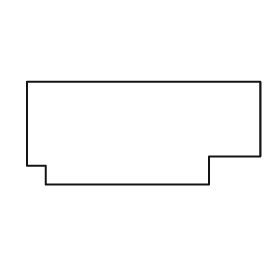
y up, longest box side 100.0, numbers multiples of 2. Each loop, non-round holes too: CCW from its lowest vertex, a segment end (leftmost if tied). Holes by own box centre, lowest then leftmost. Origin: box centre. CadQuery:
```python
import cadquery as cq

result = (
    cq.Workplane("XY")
    .moveTo(-42.0, -22.0)
    .lineTo(28.0, -22.0)
    .lineTo(28.0, -10.0)
    .lineTo(50.0, -10.0)
    .lineTo(50.0, 22.0)
    .lineTo(-50.0, 22.0)
    .lineTo(-50.0, -14.0)
    .lineTo(-42.0, -14.0)
    .close()
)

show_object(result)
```